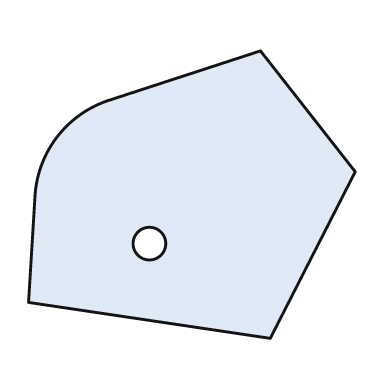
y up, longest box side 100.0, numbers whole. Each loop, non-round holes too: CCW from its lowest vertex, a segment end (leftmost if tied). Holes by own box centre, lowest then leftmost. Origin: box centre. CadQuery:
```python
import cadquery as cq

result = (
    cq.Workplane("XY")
    .moveTo(24.0, -44.0)
    .lineTo(50.0, 7.0)
    .lineTo(21.0, 44.0)
    .lineTo(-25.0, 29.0)
    .threePointArc((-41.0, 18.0), (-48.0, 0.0))
    .lineTo(-50.0, -33.0)
    .close()
    .moveTo(-13.0, -15.0)
    .circle(5.0)
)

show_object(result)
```